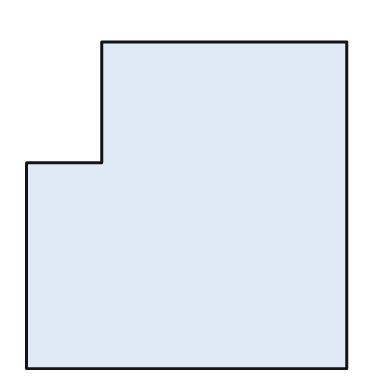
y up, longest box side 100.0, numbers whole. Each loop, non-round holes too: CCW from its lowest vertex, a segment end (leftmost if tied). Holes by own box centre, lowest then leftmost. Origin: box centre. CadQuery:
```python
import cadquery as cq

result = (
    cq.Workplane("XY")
    .moveTo(-49.0, -50.0)
    .lineTo(49.0, -50.0)
    .lineTo(49.0, 50.0)
    .lineTo(-26.0, 50.0)
    .lineTo(-26.0, 13.0)
    .lineTo(-49.0, 13.0)
    .close()
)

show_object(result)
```